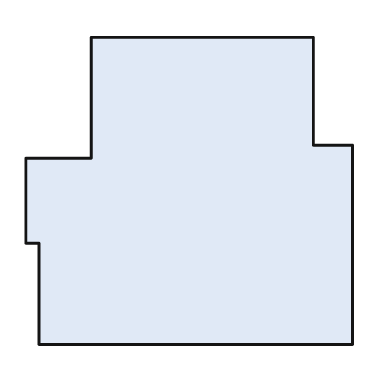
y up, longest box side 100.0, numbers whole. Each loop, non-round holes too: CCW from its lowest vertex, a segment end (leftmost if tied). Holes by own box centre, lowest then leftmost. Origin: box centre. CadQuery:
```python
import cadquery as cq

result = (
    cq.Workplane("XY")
    .moveTo(-46.0, -47.0)
    .lineTo(50.0, -47.0)
    .lineTo(50.0, 14.0)
    .lineTo(38.0, 14.0)
    .lineTo(38.0, 47.0)
    .lineTo(-30.0, 47.0)
    .lineTo(-30.0, 10.0)
    .lineTo(-50.0, 10.0)
    .lineTo(-50.0, -16.0)
    .lineTo(-46.0, -16.0)
    .close()
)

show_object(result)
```